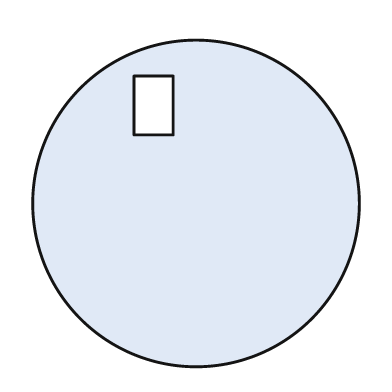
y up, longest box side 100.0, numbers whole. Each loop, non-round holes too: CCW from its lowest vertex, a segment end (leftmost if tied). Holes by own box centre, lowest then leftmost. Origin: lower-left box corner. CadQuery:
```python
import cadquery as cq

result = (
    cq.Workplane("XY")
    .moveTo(50.0, 50.0)
    .circle(50.0)
    .moveTo(31.0, 71.0)
    .lineTo(43.0, 71.0)
    .lineTo(43.0, 89.0)
    .lineTo(31.0, 89.0)
    .close()
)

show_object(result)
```